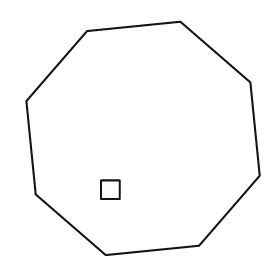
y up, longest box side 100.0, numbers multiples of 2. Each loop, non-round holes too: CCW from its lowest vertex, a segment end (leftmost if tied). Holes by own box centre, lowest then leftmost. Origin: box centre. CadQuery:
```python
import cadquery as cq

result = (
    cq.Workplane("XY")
    .moveTo(-16.0, -50.0)
    .lineTo(24.0, -46.0)
    .lineTo(50.0, -16.0)
    .lineTo(46.0, 24.0)
    .lineTo(16.0, 50.0)
    .lineTo(-24.0, 46.0)
    .lineTo(-50.0, 16.0)
    .lineTo(-46.0, -24.0)
    .close()
    .moveTo(-18.0, -26.0)
    .lineTo(-10.0, -26.0)
    .lineTo(-10.0, -18.0)
    .lineTo(-18.0, -18.0)
    .close()
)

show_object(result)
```